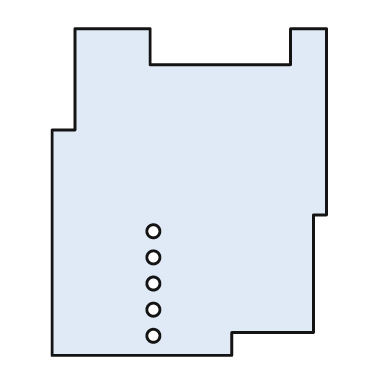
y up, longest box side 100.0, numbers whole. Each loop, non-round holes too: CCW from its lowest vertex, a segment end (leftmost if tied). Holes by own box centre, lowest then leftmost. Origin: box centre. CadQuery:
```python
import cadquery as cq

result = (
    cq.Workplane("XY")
    .moveTo(-42.0, -50.0)
    .lineTo(13.0, -50.0)
    .lineTo(13.0, -43.0)
    .lineTo(38.0, -43.0)
    .lineTo(38.0, -7.0)
    .lineTo(42.0, -7.0)
    .lineTo(42.0, 50.0)
    .lineTo(31.0, 50.0)
    .lineTo(31.0, 39.0)
    .lineTo(-12.0, 39.0)
    .lineTo(-12.0, 50.0)
    .lineTo(-35.0, 50.0)
    .lineTo(-35.0, 19.0)
    .lineTo(-42.0, 19.0)
    .close()
    .moveTo(-11.0, -44.0)
    .circle(2.0)
    .moveTo(-11.0, -36.0)
    .circle(2.0)
    .moveTo(-11.0, -28.0)
    .circle(2.0)
    .moveTo(-11.0, -20.0)
    .circle(2.0)
    .moveTo(-11.0, -12.0)
    .circle(2.0)
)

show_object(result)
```